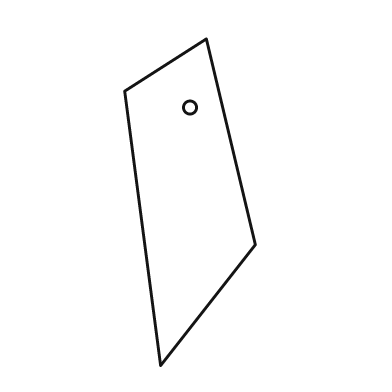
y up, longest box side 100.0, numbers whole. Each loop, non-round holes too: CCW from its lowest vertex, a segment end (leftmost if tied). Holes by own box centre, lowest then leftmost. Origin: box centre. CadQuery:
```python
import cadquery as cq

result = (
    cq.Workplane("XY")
    .moveTo(-9.0, -50.0)
    .lineTo(20.0, -13.0)
    .lineTo(5.0, 50.0)
    .lineTo(-20.0, 34.0)
    .close()
    .moveTo(0.0, 29.0)
    .circle(2.0)
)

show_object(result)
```